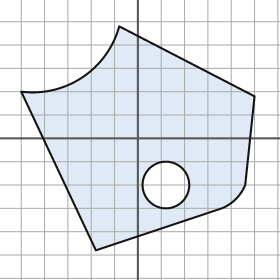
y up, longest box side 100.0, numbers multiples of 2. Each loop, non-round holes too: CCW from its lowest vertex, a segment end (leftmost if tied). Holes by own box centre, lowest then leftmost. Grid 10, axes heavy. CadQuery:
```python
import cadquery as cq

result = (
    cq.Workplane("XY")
    .moveTo(-18.0, -48.0)
    .lineTo(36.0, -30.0)
    .threePointArc((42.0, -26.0), (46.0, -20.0))
    .lineTo(50.0, 18.0)
    .lineTo(-8.0, 48.0)
    .threePointArc((-24.0, 26.0), (-50.0, 20.0))
    .close()
    .moveTo(12.0, -20.0)
    .circle(10.0)
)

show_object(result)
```